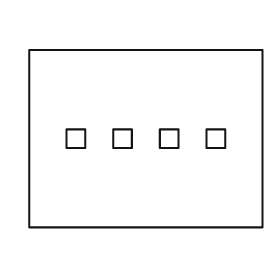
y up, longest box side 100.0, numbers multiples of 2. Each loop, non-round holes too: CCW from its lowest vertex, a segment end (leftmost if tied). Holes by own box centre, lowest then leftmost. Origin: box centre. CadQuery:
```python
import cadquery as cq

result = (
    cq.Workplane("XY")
    .moveTo(-50.0, -38.0)
    .lineTo(50.0, -38.0)
    .lineTo(50.0, 38.0)
    .lineTo(-50.0, 38.0)
    .close()
    .moveTo(-34.0, -4.0)
    .lineTo(-26.0, -4.0)
    .lineTo(-26.0, 4.0)
    .lineTo(-34.0, 4.0)
    .close()
    .moveTo(-14.0, -4.0)
    .lineTo(-6.0, -4.0)
    .lineTo(-6.0, 4.0)
    .lineTo(-14.0, 4.0)
    .close()
    .moveTo(6.0, -4.0)
    .lineTo(14.0, -4.0)
    .lineTo(14.0, 4.0)
    .lineTo(6.0, 4.0)
    .close()
    .moveTo(26.0, -4.0)
    .lineTo(34.0, -4.0)
    .lineTo(34.0, 4.0)
    .lineTo(26.0, 4.0)
    .close()
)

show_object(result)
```